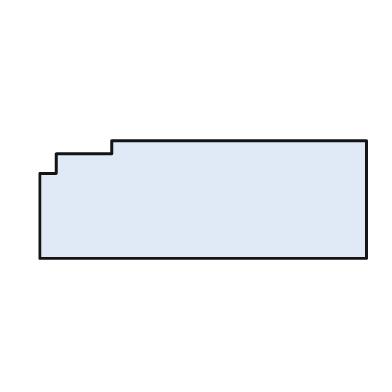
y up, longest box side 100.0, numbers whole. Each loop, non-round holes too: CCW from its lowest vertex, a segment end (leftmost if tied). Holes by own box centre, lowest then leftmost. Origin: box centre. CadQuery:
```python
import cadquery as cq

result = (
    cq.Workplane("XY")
    .moveTo(-50.0, -18.0)
    .lineTo(50.0, -18.0)
    .lineTo(50.0, 18.0)
    .lineTo(-28.0, 18.0)
    .lineTo(-28.0, 14.0)
    .lineTo(-45.0, 14.0)
    .lineTo(-45.0, 8.0)
    .lineTo(-50.0, 8.0)
    .close()
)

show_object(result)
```